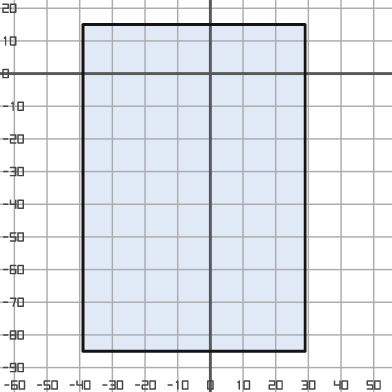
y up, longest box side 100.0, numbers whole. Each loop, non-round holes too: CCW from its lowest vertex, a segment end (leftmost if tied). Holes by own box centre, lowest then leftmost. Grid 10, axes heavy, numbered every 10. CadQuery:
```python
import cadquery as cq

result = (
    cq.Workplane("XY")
    .moveTo(-39.0, -85.0)
    .lineTo(29.0, -85.0)
    .lineTo(29.0, 15.0)
    .lineTo(-39.0, 15.0)
    .close()
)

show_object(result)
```